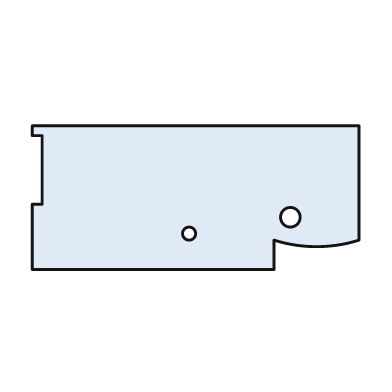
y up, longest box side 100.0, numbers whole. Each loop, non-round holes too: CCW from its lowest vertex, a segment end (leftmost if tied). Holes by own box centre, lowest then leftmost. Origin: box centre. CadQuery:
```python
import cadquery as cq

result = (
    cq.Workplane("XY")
    .moveTo(-50.0, -22.0)
    .lineTo(24.0, -22.0)
    .lineTo(24.0, -13.0)
    .threePointArc((37.0, -15.0), (50.0, -13.0))
    .lineTo(50.0, 22.0)
    .lineTo(-50.0, 22.0)
    .lineTo(-50.0, 19.0)
    .lineTo(-47.0, 19.0)
    .lineTo(-47.0, -2.0)
    .lineTo(-50.0, -2.0)
    .close()
    .moveTo(-2.0, -11.0)
    .circle(2.0)
    .moveTo(29.0, -6.0)
    .circle(3.0)
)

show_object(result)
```